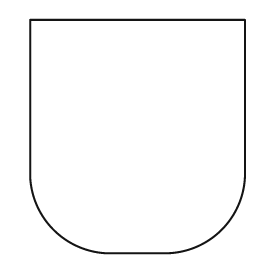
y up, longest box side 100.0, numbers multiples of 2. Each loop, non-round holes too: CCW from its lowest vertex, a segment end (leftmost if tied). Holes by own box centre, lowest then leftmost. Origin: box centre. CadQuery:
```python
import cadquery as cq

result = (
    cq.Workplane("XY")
    .moveTo(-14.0, -50.0)
    .lineTo(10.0, -50.0)
    .threePointArc((36.0, -40.0), (46.0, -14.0))
    .lineTo(46.0, 50.0)
    .lineTo(-46.0, 50.0)
    .lineTo(-46.0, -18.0)
    .threePointArc((-36.0, -40.0), (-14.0, -50.0))
    .close()
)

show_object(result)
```